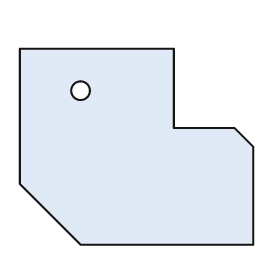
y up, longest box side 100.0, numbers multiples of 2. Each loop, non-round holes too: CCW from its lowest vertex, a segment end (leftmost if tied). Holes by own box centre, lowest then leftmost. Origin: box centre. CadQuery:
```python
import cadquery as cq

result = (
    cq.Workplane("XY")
    .moveTo(-24.0, -42.0)
    .lineTo(50.0, -42.0)
    .lineTo(50.0, 0.0)
    .lineTo(42.0, 8.0)
    .lineTo(16.0, 8.0)
    .lineTo(16.0, 42.0)
    .lineTo(-50.0, 42.0)
    .lineTo(-50.0, -16.0)
    .close()
    .moveTo(-24.0, 24.0)
    .circle(4.0)
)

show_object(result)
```